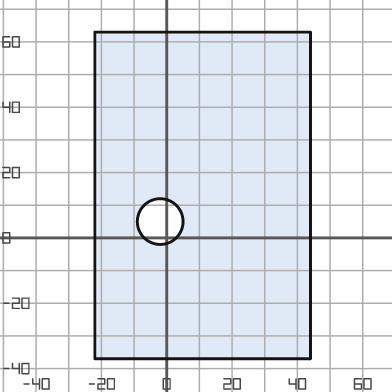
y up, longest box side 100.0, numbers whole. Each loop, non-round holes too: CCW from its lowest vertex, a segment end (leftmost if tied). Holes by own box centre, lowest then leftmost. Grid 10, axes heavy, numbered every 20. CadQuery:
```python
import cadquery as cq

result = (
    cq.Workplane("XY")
    .moveTo(-22.0, -37.0)
    .lineTo(44.0, -37.0)
    .lineTo(44.0, 63.0)
    .lineTo(-22.0, 63.0)
    .close()
    .moveTo(-2.0, 5.0)
    .circle(7.0)
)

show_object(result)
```